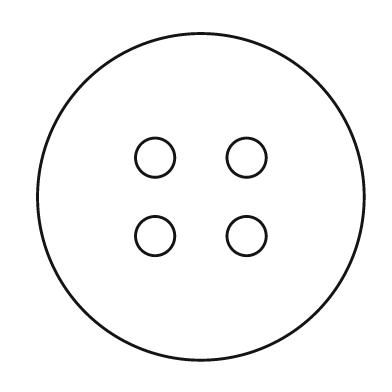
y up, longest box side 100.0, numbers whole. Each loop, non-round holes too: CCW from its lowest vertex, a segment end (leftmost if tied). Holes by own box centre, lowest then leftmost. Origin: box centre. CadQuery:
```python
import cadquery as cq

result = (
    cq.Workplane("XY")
    .moveTo(0.0, 0.0)
    .circle(50.0)
    .moveTo(-14.0, -12.0)
    .circle(6.0)
    .moveTo(14.0, -12.0)
    .circle(6.0)
    .moveTo(-14.0, 12.0)
    .circle(6.0)
    .moveTo(14.0, 12.0)
    .circle(6.0)
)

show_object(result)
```